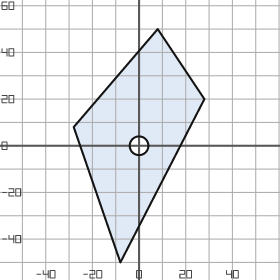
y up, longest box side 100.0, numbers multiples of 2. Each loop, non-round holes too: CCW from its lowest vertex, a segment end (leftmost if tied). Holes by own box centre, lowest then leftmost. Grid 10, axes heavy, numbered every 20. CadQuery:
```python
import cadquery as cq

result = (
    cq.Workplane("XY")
    .moveTo(-8.0, -50.0)
    .lineTo(28.0, 20.0)
    .lineTo(8.0, 50.0)
    .lineTo(-28.0, 8.0)
    .close()
    .moveTo(0.0, 0.0)
    .circle(4.0)
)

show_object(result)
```